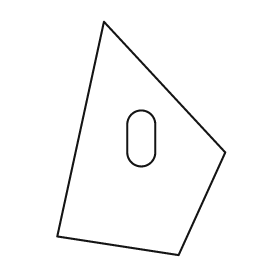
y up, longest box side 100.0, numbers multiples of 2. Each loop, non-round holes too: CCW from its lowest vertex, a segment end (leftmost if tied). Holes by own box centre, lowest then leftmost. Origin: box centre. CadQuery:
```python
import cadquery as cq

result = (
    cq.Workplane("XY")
    .moveTo(16.0, -50.0)
    .lineTo(36.0, -6.0)
    .lineTo(-16.0, 50.0)
    .lineTo(-36.0, -42.0)
    .close()
    .moveTo(-6.0, -6.0)
    .threePointArc((0.0, -12.0), (6.0, -6.0))
    .lineTo(6.0, 6.0)
    .threePointArc((0.0, 12.0), (-6.0, 6.0))
    .close()
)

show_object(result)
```